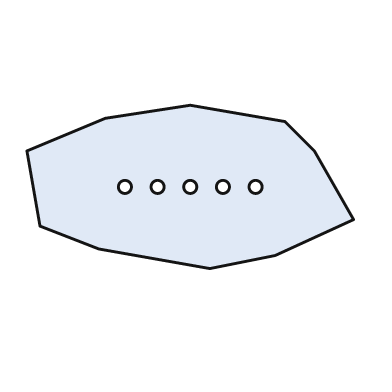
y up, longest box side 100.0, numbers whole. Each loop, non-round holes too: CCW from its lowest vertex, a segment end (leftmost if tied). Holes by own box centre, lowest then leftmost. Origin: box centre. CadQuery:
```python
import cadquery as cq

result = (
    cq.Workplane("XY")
    .moveTo(6.0, -25.0)
    .lineTo(26.0, -21.0)
    .lineTo(50.0, -10.0)
    .lineTo(38.0, 11.0)
    .lineTo(29.0, 20.0)
    .lineTo(0.0, 25.0)
    .lineTo(-26.0, 21.0)
    .lineTo(-50.0, 11.0)
    .lineTo(-46.0, -12.0)
    .lineTo(-28.0, -19.0)
    .close()
    .moveTo(-20.0, 0.0)
    .circle(2.0)
    .moveTo(-10.0, 0.0)
    .circle(2.0)
    .moveTo(0.0, 0.0)
    .circle(2.0)
    .moveTo(10.0, 0.0)
    .circle(2.0)
    .moveTo(20.0, 0.0)
    .circle(2.0)
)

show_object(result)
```